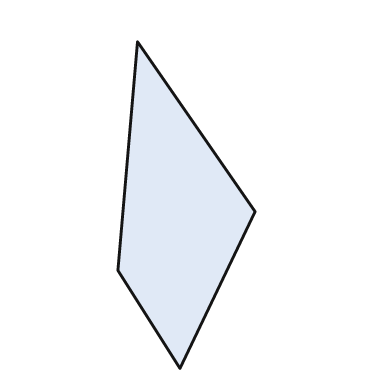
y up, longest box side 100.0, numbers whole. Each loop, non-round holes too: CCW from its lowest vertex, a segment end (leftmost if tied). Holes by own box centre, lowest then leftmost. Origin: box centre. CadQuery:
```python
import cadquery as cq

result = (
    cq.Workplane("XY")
    .moveTo(-2.0, -50.0)
    .lineTo(21.0, -2.0)
    .lineTo(-15.0, 50.0)
    .lineTo(-21.0, -20.0)
    .close()
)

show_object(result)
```